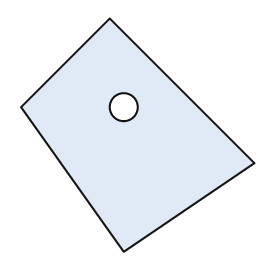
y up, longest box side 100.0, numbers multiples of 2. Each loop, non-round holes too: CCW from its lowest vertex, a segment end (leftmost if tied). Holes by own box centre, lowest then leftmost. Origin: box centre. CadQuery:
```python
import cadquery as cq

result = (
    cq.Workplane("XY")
    .moveTo(-6.0, -50.0)
    .lineTo(50.0, -12.0)
    .lineTo(-12.0, 50.0)
    .lineTo(-50.0, 12.0)
    .close()
    .moveTo(-6.0, 12.0)
    .circle(6.0)
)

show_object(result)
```